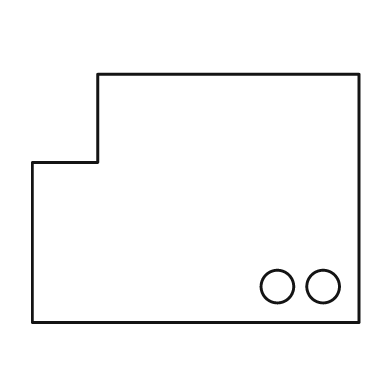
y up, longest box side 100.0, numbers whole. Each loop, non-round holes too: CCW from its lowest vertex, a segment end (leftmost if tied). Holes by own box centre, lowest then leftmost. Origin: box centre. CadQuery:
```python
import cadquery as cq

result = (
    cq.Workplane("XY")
    .moveTo(-50.0, -38.0)
    .lineTo(50.0, -38.0)
    .lineTo(50.0, 38.0)
    .lineTo(-30.0, 38.0)
    .lineTo(-30.0, 11.0)
    .lineTo(-50.0, 11.0)
    .close()
    .moveTo(25.0, -27.0)
    .circle(5.0)
    .moveTo(39.0, -27.0)
    .circle(5.0)
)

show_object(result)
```